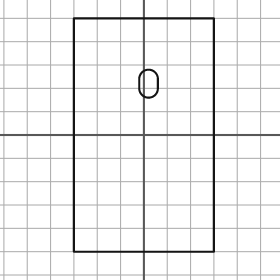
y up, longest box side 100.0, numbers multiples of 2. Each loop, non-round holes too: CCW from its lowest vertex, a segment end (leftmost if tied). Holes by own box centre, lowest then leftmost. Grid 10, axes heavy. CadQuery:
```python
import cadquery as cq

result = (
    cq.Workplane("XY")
    .moveTo(-30.0, -50.0)
    .lineTo(30.0, -50.0)
    .lineTo(30.0, 50.0)
    .lineTo(-30.0, 50.0)
    .close()
    .moveTo(-2.0, 20.0)
    .threePointArc((2.0, 16.0), (6.0, 20.0))
    .lineTo(6.0, 24.0)
    .threePointArc((2.0, 28.0), (-2.0, 24.0))
    .close()
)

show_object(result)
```